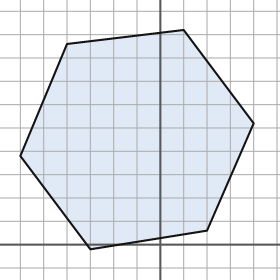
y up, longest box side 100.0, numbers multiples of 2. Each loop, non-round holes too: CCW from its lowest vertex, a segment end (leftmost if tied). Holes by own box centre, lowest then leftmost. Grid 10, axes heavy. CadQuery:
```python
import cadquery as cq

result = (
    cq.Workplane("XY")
    .moveTo(-30.0, -2.0)
    .lineTo(20.0, 6.0)
    .lineTo(40.0, 52.0)
    .lineTo(10.0, 92.0)
    .lineTo(-40.0, 86.0)
    .lineTo(-60.0, 38.0)
    .close()
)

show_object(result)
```